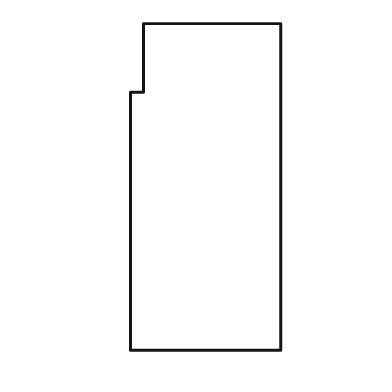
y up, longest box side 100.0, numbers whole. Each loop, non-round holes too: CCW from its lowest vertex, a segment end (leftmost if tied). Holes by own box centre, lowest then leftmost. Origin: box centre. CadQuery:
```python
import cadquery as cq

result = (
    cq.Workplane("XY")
    .moveTo(-23.0, -50.0)
    .lineTo(23.0, -50.0)
    .lineTo(23.0, 50.0)
    .lineTo(-19.0, 50.0)
    .lineTo(-19.0, 29.0)
    .lineTo(-23.0, 29.0)
    .close()
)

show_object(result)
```